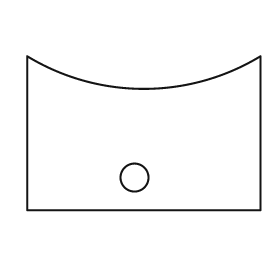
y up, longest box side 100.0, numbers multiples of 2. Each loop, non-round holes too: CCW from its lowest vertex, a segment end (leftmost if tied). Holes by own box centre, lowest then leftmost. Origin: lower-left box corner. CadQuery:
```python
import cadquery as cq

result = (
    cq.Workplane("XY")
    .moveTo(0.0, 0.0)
    .lineTo(100.0, 0.0)
    .lineTo(100.0, 66.0)
    .threePointArc((50.0, 52.0), (0.0, 66.0))
    .close()
    .moveTo(46.0, 14.0)
    .circle(6.0)
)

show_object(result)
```